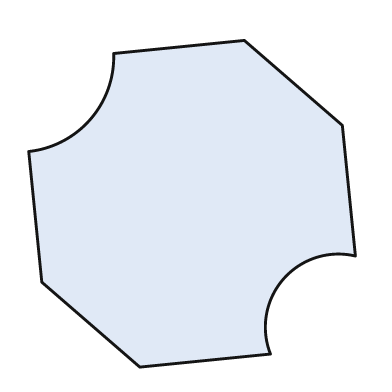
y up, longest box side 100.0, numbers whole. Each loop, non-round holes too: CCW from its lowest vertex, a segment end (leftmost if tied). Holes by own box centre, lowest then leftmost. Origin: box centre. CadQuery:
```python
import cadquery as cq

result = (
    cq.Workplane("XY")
    .moveTo(-16.0, -50.0)
    .lineTo(24.0, -46.0)
    .threePointArc((28.0, -23.0), (50.0, -16.0))
    .lineTo(46.0, 24.0)
    .lineTo(16.0, 50.0)
    .lineTo(-24.0, 46.0)
    .threePointArc((-31.0, 26.0), (-50.0, 16.0))
    .lineTo(-46.0, -24.0)
    .close()
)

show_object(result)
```